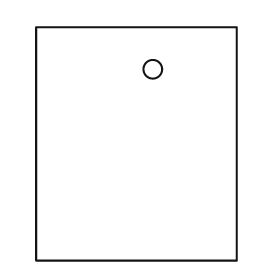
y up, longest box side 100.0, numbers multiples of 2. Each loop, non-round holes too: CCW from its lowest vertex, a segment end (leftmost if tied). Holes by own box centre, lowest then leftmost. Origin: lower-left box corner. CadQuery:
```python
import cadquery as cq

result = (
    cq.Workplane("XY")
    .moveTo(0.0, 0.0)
    .lineTo(86.0, 0.0)
    .lineTo(86.0, 100.0)
    .lineTo(0.0, 100.0)
    .close()
    .moveTo(50.0, 82.0)
    .circle(4.0)
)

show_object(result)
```